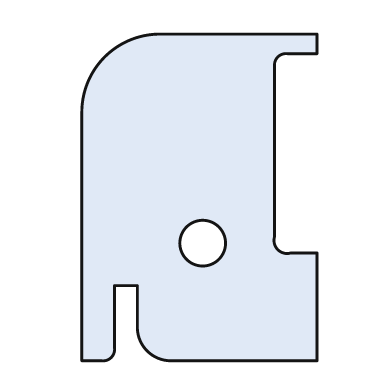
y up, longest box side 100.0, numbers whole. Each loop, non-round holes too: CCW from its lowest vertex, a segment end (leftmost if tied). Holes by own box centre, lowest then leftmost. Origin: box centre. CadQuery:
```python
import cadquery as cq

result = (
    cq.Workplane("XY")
    .moveTo(-36.0, -50.0)
    .lineTo(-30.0, -50.0)
    .threePointArc((-27.0, -49.0), (-26.0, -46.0))
    .lineTo(-26.0, -27.0)
    .lineTo(-19.0, -27.0)
    .lineTo(-19.0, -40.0)
    .threePointArc((-16.0, -47.0), (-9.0, -50.0))
    .lineTo(36.0, -50.0)
    .lineTo(36.0, -17.0)
    .lineTo(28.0, -17.0)
    .threePointArc((24.0, -16.0), (23.0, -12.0))
    .lineTo(23.0, 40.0)
    .threePointArc((24.0, 43.0), (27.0, 44.0))
    .lineTo(36.0, 44.0)
    .lineTo(36.0, 50.0)
    .lineTo(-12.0, 50.0)
    .threePointArc((-29.0, 43.0), (-36.0, 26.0))
    .close()
    .moveTo(1.0, -14.0)
    .circle(7.0)
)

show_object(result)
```